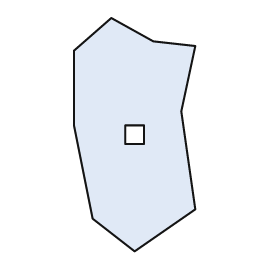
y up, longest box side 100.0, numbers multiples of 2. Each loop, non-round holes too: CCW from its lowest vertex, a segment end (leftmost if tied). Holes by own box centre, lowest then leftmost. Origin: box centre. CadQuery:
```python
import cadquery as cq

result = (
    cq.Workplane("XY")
    .moveTo(0.0, -50.0)
    .lineTo(26.0, -32.0)
    .lineTo(20.0, 10.0)
    .lineTo(26.0, 38.0)
    .lineTo(8.0, 40.0)
    .lineTo(-10.0, 50.0)
    .lineTo(-26.0, 36.0)
    .lineTo(-26.0, 4.0)
    .lineTo(-18.0, -36.0)
    .close()
    .moveTo(-4.0, -4.0)
    .lineTo(4.0, -4.0)
    .lineTo(4.0, 4.0)
    .lineTo(-4.0, 4.0)
    .close()
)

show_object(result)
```